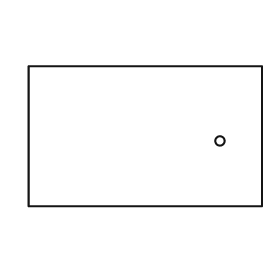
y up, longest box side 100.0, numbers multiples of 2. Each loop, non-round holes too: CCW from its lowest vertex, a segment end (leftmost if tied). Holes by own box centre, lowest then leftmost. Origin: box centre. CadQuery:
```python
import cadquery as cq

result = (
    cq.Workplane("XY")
    .moveTo(-50.0, -30.0)
    .lineTo(50.0, -30.0)
    .lineTo(50.0, 30.0)
    .lineTo(-50.0, 30.0)
    .close()
    .moveTo(32.0, -2.0)
    .circle(2.0)
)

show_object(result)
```